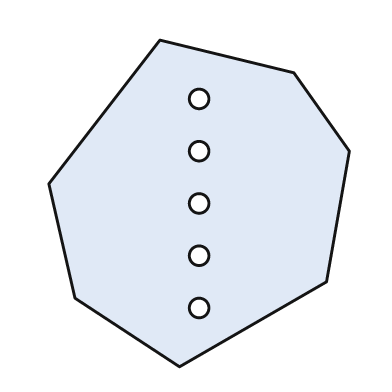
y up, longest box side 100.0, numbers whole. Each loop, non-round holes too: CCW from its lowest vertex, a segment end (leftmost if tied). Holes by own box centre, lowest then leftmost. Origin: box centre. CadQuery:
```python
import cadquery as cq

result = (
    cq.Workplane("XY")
    .moveTo(-6.0, -50.0)
    .lineTo(39.0, -24.0)
    .lineTo(46.0, 16.0)
    .lineTo(29.0, 40.0)
    .lineTo(-12.0, 50.0)
    .lineTo(-46.0, 6.0)
    .lineTo(-38.0, -29.0)
    .close()
    .moveTo(0.0, -32.0)
    .circle(3.0)
    .moveTo(0.0, -16.0)
    .circle(3.0)
    .moveTo(0.0, 0.0)
    .circle(3.0)
    .moveTo(0.0, 16.0)
    .circle(3.0)
    .moveTo(0.0, 32.0)
    .circle(3.0)
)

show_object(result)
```